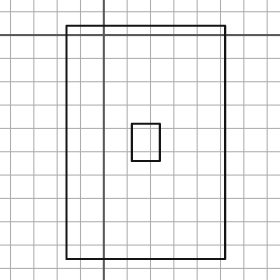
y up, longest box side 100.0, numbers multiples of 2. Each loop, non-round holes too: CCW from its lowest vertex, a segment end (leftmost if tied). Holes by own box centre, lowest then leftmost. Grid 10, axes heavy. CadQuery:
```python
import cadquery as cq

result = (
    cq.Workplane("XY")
    .moveTo(-16.0, -96.0)
    .lineTo(52.0, -96.0)
    .lineTo(52.0, 4.0)
    .lineTo(-16.0, 4.0)
    .close()
    .moveTo(12.0, -54.0)
    .lineTo(24.0, -54.0)
    .lineTo(24.0, -38.0)
    .lineTo(12.0, -38.0)
    .close()
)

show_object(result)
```